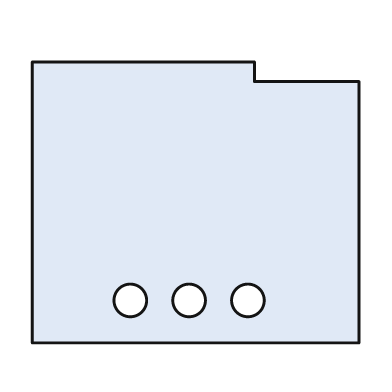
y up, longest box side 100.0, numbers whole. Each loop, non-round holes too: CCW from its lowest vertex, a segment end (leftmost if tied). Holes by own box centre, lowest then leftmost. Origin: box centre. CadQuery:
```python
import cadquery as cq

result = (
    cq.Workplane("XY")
    .moveTo(-50.0, -43.0)
    .lineTo(50.0, -43.0)
    .lineTo(50.0, 37.0)
    .lineTo(18.0, 37.0)
    .lineTo(18.0, 43.0)
    .lineTo(-50.0, 43.0)
    .close()
    .moveTo(-20.0, -30.0)
    .circle(5.0)
    .moveTo(-2.0, -30.0)
    .circle(5.0)
    .moveTo(16.0, -30.0)
    .circle(5.0)
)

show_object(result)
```